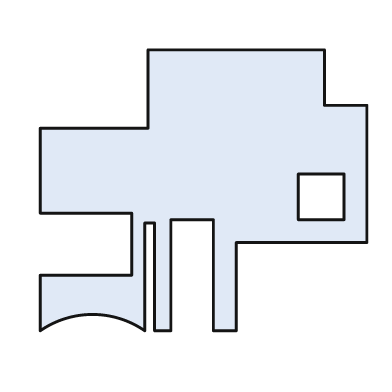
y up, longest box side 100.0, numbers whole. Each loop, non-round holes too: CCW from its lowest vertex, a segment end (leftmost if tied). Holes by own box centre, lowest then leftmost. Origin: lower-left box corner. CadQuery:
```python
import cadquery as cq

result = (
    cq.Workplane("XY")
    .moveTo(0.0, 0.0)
    .threePointArc((16.0, 5.0), (32.0, 0.0))
    .lineTo(32.0, 33.0)
    .lineTo(35.0, 33.0)
    .lineTo(35.0, 0.0)
    .lineTo(40.0, 0.0)
    .lineTo(40.0, 34.0)
    .lineTo(53.0, 34.0)
    .lineTo(53.0, 0.0)
    .lineTo(60.0, 0.0)
    .lineTo(60.0, 27.0)
    .lineTo(100.0, 27.0)
    .lineTo(100.0, 69.0)
    .lineTo(87.0, 69.0)
    .lineTo(87.0, 86.0)
    .lineTo(33.0, 86.0)
    .lineTo(33.0, 62.0)
    .lineTo(0.0, 62.0)
    .lineTo(0.0, 36.0)
    .lineTo(28.0, 36.0)
    .lineTo(28.0, 17.0)
    .lineTo(0.0, 17.0)
    .close()
    .moveTo(79.0, 34.0)
    .lineTo(93.0, 34.0)
    .lineTo(93.0, 48.0)
    .lineTo(79.0, 48.0)
    .close()
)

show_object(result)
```